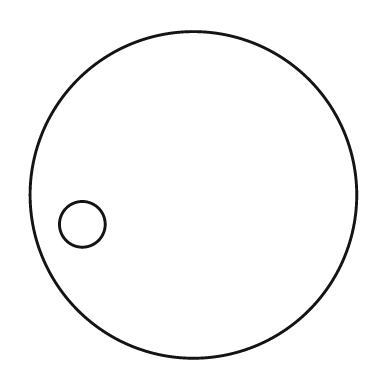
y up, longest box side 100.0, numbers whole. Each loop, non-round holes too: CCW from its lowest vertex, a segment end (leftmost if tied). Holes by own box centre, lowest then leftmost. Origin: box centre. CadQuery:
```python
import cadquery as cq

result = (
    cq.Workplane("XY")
    .moveTo(0.0, 0.0)
    .circle(50.0)
    .moveTo(-34.0, -9.0)
    .circle(7.0)
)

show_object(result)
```